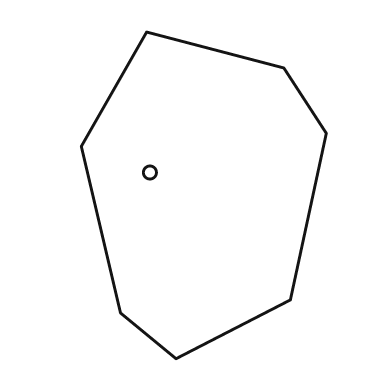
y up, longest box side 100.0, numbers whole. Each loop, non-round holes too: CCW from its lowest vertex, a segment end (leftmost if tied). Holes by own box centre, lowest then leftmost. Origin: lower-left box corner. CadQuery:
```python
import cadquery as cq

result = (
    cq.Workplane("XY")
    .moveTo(29.0, 0.0)
    .lineTo(64.0, 18.0)
    .lineTo(75.0, 69.0)
    .lineTo(62.0, 89.0)
    .lineTo(20.0, 100.0)
    .lineTo(0.0, 65.0)
    .lineTo(12.0, 14.0)
    .close()
    .moveTo(21.0, 57.0)
    .circle(2.0)
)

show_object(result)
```